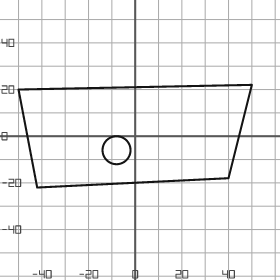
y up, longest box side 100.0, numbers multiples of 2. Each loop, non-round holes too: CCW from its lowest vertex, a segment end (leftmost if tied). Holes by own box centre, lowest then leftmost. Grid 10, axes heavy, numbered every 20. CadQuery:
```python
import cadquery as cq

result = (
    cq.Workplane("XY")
    .moveTo(-42.0, -22.0)
    .lineTo(40.0, -18.0)
    .lineTo(50.0, 22.0)
    .lineTo(-50.0, 20.0)
    .close()
    .moveTo(-8.0, -6.0)
    .circle(6.0)
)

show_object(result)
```